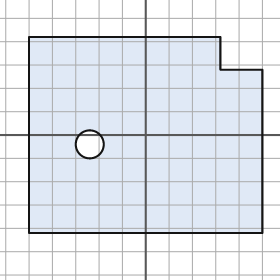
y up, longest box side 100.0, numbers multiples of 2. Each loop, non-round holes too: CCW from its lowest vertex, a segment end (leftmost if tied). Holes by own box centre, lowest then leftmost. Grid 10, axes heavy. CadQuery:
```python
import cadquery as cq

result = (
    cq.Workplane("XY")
    .moveTo(-50.0, -42.0)
    .lineTo(50.0, -42.0)
    .lineTo(50.0, 28.0)
    .lineTo(32.0, 28.0)
    .lineTo(32.0, 42.0)
    .lineTo(-50.0, 42.0)
    .close()
    .moveTo(-24.0, -4.0)
    .circle(6.0)
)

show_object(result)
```